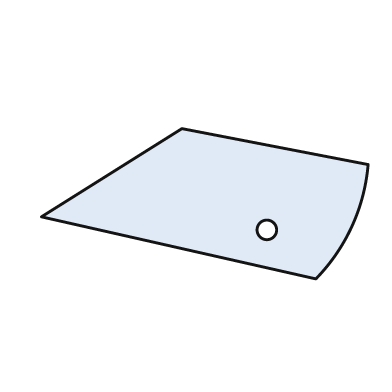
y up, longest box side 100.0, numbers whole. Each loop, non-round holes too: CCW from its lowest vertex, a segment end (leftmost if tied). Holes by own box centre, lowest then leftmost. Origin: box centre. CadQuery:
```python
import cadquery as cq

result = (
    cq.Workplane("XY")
    .moveTo(34.0, -23.0)
    .threePointArc((45.0, -7.0), (50.0, 12.0))
    .lineTo(-7.0, 23.0)
    .lineTo(-50.0, -4.0)
    .close()
    .moveTo(19.0, -8.0)
    .circle(3.0)
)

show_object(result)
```